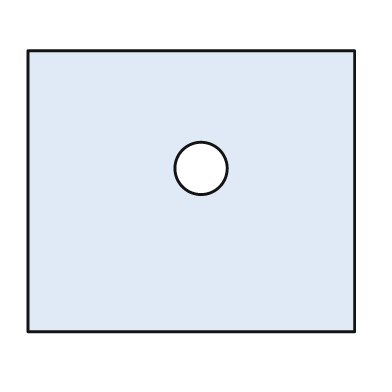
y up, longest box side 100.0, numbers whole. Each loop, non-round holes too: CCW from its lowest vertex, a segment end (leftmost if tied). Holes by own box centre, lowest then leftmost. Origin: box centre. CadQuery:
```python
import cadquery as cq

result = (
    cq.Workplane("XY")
    .moveTo(-50.0, -43.0)
    .lineTo(50.0, -43.0)
    .lineTo(50.0, 43.0)
    .lineTo(-50.0, 43.0)
    .close()
    .moveTo(3.0, 7.0)
    .circle(8.0)
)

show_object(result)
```